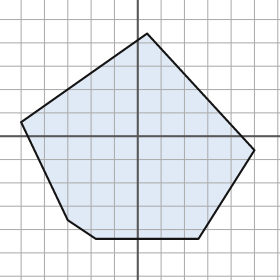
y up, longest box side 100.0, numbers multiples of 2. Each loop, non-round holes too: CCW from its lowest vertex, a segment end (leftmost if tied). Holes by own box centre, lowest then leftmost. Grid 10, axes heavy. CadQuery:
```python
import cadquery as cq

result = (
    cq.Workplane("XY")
    .moveTo(-18.0, -44.0)
    .lineTo(26.0, -44.0)
    .lineTo(50.0, -6.0)
    .lineTo(4.0, 44.0)
    .lineTo(-50.0, 6.0)
    .lineTo(-30.0, -36.0)
    .close()
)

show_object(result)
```